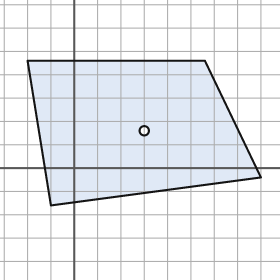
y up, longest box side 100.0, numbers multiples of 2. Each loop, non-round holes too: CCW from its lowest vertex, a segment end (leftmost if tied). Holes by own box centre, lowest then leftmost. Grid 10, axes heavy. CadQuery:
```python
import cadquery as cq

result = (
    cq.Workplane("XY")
    .moveTo(-10.0, -16.0)
    .lineTo(80.0, -4.0)
    .lineTo(56.0, 46.0)
    .lineTo(-20.0, 46.0)
    .close()
    .moveTo(30.0, 16.0)
    .circle(2.0)
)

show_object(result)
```